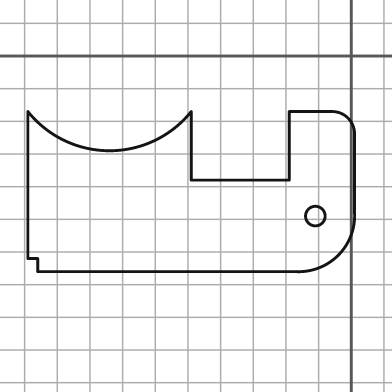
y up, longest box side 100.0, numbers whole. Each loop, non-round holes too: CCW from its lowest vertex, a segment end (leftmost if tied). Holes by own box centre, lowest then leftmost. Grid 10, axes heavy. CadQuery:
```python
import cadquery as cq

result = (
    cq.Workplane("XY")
    .moveTo(-96.0, -66.0)
    .lineTo(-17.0, -66.0)
    .threePointArc((-4.0, -61.0), (1.0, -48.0))
    .lineTo(1.0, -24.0)
    .threePointArc((-1.0, -19.0), (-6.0, -17.0))
    .lineTo(-19.0, -17.0)
    .lineTo(-19.0, -38.0)
    .lineTo(-49.0, -38.0)
    .lineTo(-49.0, -17.0)
    .threePointArc((-74.0, -29.0), (-99.0, -17.0))
    .lineTo(-99.0, -62.0)
    .lineTo(-96.0, -62.0)
    .close()
    .moveTo(-11.0, -49.0)
    .circle(3.0)
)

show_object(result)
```